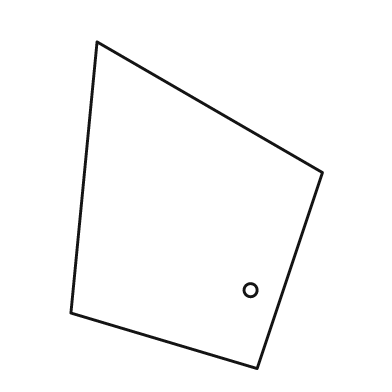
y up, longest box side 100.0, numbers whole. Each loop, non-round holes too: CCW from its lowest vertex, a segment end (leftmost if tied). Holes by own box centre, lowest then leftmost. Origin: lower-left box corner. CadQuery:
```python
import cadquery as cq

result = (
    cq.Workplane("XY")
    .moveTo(57.0, 0.0)
    .lineTo(77.0, 60.0)
    .lineTo(8.0, 100.0)
    .lineTo(0.0, 17.0)
    .close()
    .moveTo(55.0, 24.0)
    .circle(2.0)
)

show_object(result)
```